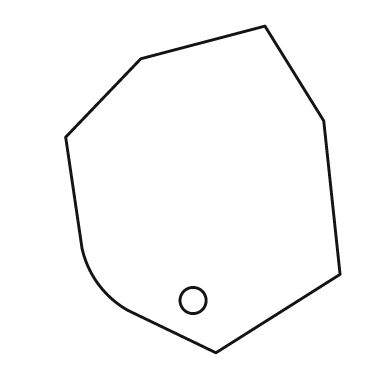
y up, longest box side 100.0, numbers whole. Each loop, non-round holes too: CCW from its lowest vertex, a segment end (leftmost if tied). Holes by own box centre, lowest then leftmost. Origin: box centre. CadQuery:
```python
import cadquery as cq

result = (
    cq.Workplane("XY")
    .moveTo(4.0, -50.0)
    .lineTo(42.0, -26.0)
    .lineTo(37.0, 21.0)
    .lineTo(19.0, 50.0)
    .lineTo(-19.0, 40.0)
    .lineTo(-42.0, 16.0)
    .lineTo(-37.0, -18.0)
    .threePointArc((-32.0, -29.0), (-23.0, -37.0))
    .close()
    .moveTo(-3.0, -34.0)
    .circle(4.0)
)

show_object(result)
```